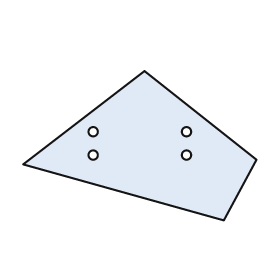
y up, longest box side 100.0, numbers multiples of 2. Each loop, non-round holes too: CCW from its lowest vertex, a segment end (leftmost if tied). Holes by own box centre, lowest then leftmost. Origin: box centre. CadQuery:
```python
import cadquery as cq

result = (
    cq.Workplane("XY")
    .moveTo(36.0, -32.0)
    .lineTo(50.0, -6.0)
    .lineTo(2.0, 32.0)
    .lineTo(-50.0, -8.0)
    .close()
    .moveTo(-20.0, -4.0)
    .circle(2.0)
    .moveTo(20.0, -4.0)
    .circle(2.0)
    .moveTo(-20.0, 6.0)
    .circle(2.0)
    .moveTo(20.0, 6.0)
    .circle(2.0)
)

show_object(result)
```